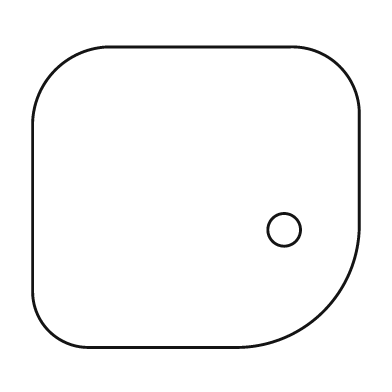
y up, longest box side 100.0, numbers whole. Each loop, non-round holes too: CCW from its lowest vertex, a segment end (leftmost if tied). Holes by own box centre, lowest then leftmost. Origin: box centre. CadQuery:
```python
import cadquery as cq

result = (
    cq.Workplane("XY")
    .moveTo(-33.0, -46.0)
    .lineTo(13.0, -46.0)
    .threePointArc((39.0, -35.0), (50.0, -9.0))
    .lineTo(50.0, 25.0)
    .threePointArc((44.0, 40.0), (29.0, 46.0))
    .lineTo(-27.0, 46.0)
    .threePointArc((-43.0, 39.0), (-50.0, 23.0))
    .lineTo(-50.0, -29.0)
    .threePointArc((-45.0, -41.0), (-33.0, -46.0))
    .close()
    .moveTo(27.0, -10.0)
    .circle(5.0)
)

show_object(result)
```